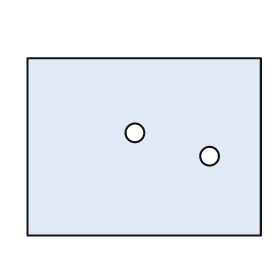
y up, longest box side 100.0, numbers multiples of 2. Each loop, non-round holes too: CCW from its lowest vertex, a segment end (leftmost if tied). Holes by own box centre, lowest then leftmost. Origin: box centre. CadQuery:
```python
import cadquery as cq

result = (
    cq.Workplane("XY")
    .moveTo(-50.0, -38.0)
    .lineTo(50.0, -38.0)
    .lineTo(50.0, 38.0)
    .lineTo(-50.0, 38.0)
    .close()
    .moveTo(28.0, -4.0)
    .circle(4.0)
    .moveTo(-4.0, 6.0)
    .circle(4.0)
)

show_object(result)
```